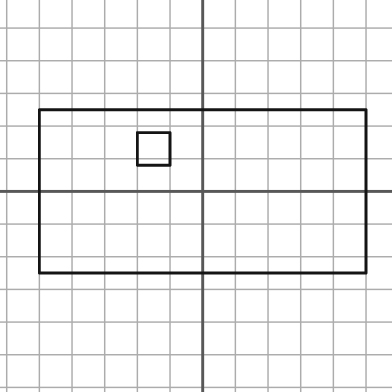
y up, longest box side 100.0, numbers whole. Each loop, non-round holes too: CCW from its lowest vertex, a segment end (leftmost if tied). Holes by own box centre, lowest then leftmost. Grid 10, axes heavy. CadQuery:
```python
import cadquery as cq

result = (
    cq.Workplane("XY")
    .moveTo(-50.0, -25.0)
    .lineTo(50.0, -25.0)
    .lineTo(50.0, 25.0)
    .lineTo(-50.0, 25.0)
    .close()
    .moveTo(-20.0, 8.0)
    .lineTo(-10.0, 8.0)
    .lineTo(-10.0, 18.0)
    .lineTo(-20.0, 18.0)
    .close()
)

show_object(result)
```